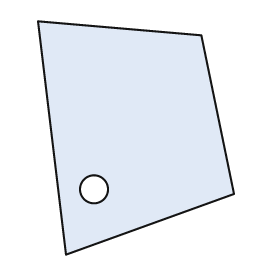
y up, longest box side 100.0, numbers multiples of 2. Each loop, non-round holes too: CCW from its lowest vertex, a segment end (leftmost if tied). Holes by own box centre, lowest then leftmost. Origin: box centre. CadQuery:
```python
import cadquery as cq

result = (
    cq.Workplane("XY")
    .moveTo(-30.0, -50.0)
    .lineTo(42.0, -24.0)
    .lineTo(28.0, 44.0)
    .lineTo(-42.0, 50.0)
    .close()
    .moveTo(-18.0, -22.0)
    .circle(6.0)
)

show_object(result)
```